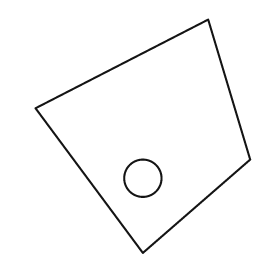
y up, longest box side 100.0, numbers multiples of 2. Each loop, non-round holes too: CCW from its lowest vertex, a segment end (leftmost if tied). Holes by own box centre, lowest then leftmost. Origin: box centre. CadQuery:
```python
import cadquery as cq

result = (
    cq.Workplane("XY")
    .moveTo(0.0, -50.0)
    .lineTo(46.0, -10.0)
    .lineTo(28.0, 50.0)
    .lineTo(-46.0, 12.0)
    .close()
    .moveTo(0.0, -18.0)
    .circle(8.0)
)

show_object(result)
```